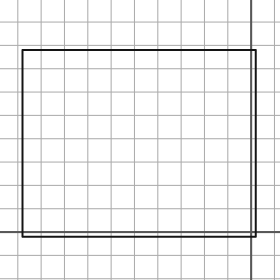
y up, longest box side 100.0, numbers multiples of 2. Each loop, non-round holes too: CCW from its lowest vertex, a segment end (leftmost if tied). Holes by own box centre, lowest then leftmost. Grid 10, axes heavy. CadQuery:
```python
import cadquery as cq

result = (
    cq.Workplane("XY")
    .moveTo(-98.0, -2.0)
    .lineTo(2.0, -2.0)
    .lineTo(2.0, 78.0)
    .lineTo(-98.0, 78.0)
    .close()
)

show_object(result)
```